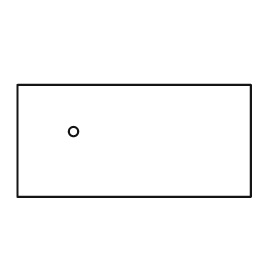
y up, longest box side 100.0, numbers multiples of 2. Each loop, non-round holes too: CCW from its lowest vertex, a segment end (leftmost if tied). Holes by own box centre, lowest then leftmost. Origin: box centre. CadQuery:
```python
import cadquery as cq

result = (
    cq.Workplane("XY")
    .moveTo(-50.0, -24.0)
    .lineTo(50.0, -24.0)
    .lineTo(50.0, 24.0)
    .lineTo(-50.0, 24.0)
    .close()
    .moveTo(-26.0, 4.0)
    .circle(2.0)
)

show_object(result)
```